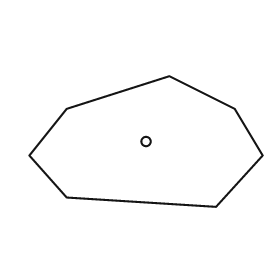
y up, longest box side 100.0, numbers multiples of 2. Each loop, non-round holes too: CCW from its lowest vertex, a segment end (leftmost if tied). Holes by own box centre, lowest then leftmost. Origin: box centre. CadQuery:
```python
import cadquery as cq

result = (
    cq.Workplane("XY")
    .moveTo(30.0, -28.0)
    .lineTo(50.0, -6.0)
    .lineTo(38.0, 14.0)
    .lineTo(10.0, 28.0)
    .lineTo(-34.0, 14.0)
    .lineTo(-50.0, -6.0)
    .lineTo(-34.0, -24.0)
    .close()
    .moveTo(0.0, 0.0)
    .circle(2.0)
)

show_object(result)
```